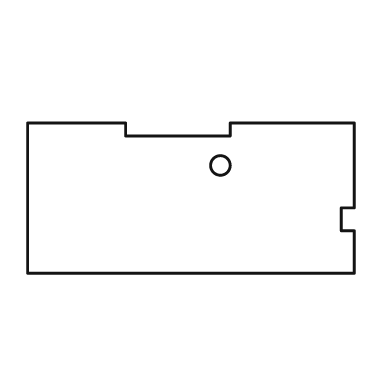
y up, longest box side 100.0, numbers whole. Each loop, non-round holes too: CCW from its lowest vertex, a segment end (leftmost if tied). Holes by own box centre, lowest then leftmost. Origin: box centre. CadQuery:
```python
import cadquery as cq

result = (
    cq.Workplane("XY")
    .moveTo(-50.0, -23.0)
    .lineTo(50.0, -23.0)
    .lineTo(50.0, -10.0)
    .lineTo(46.0, -10.0)
    .lineTo(46.0, -3.0)
    .lineTo(50.0, -3.0)
    .lineTo(50.0, 23.0)
    .lineTo(12.0, 23.0)
    .lineTo(12.0, 19.0)
    .lineTo(-20.0, 19.0)
    .lineTo(-20.0, 23.0)
    .lineTo(-50.0, 23.0)
    .close()
    .moveTo(9.0, 10.0)
    .circle(3.0)
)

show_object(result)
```